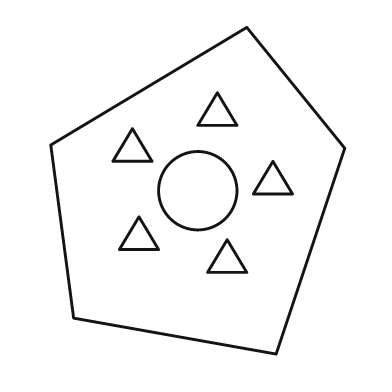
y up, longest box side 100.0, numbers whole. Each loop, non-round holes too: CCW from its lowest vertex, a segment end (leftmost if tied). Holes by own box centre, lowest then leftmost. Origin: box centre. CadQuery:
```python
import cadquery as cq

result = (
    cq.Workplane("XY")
    .moveTo(24.0, -50.0)
    .lineTo(45.0, 13.0)
    .lineTo(15.0, 50.0)
    .lineTo(-45.0, 14.0)
    .lineTo(-38.0, -39.0)
    .close()
    .moveTo(3.0, -25.0)
    .lineTo(15.0, -25.0)
    .lineTo(9.0, -15.0)
    .close()
    .moveTo(-24.0, -18.0)
    .lineTo(-12.0, -18.0)
    .lineTo(-18.0, -8.0)
    .close()
    .moveTo(0.0, 0.0)
    .circle(12.0)
    .moveTo(17.0, -1.0)
    .lineTo(29.0, -1.0)
    .lineTo(23.0, 9.0)
    .close()
    .moveTo(-26.0, 9.0)
    .lineTo(-14.0, 9.0)
    .lineTo(-20.0, 19.0)
    .close()
    .moveTo(0.0, 20.0)
    .lineTo(12.0, 20.0)
    .lineTo(6.0, 30.0)
    .close()
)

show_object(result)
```